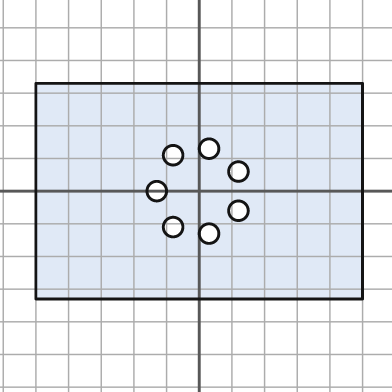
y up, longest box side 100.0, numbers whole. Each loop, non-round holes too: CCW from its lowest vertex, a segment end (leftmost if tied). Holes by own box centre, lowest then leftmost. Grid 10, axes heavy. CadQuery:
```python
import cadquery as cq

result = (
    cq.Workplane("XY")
    .moveTo(-50.0, -33.0)
    .lineTo(50.0, -33.0)
    .lineTo(50.0, 33.0)
    .lineTo(-50.0, 33.0)
    .close()
    .moveTo(3.0, -13.0)
    .circle(3.0)
    .moveTo(-8.0, -11.0)
    .circle(3.0)
    .moveTo(12.0, -6.0)
    .circle(3.0)
    .moveTo(-13.0, 0.0)
    .circle(3.0)
    .moveTo(12.0, 6.0)
    .circle(3.0)
    .moveTo(-8.0, 11.0)
    .circle(3.0)
    .moveTo(3.0, 13.0)
    .circle(3.0)
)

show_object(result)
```